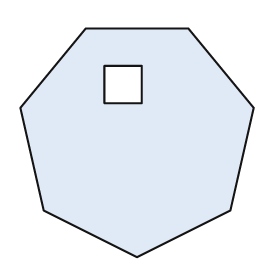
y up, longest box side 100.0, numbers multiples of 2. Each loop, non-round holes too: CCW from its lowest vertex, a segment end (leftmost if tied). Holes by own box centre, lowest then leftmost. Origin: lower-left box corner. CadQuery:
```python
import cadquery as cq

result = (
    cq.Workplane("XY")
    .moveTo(50.0, 0.0)
    .lineTo(90.0, 20.0)
    .lineTo(100.0, 64.0)
    .lineTo(72.0, 98.0)
    .lineTo(28.0, 98.0)
    .lineTo(0.0, 64.0)
    .lineTo(10.0, 20.0)
    .close()
    .moveTo(36.0, 66.0)
    .lineTo(52.0, 66.0)
    .lineTo(52.0, 82.0)
    .lineTo(36.0, 82.0)
    .close()
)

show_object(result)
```